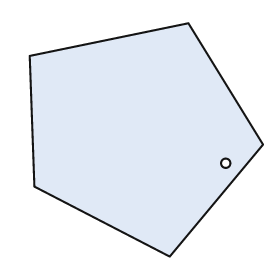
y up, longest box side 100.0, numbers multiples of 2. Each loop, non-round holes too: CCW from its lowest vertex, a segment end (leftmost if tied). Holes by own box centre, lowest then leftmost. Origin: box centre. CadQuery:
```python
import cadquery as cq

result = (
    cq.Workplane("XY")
    .moveTo(10.0, -50.0)
    .lineTo(50.0, -2.0)
    .lineTo(18.0, 50.0)
    .lineTo(-50.0, 36.0)
    .lineTo(-48.0, -20.0)
    .close()
    .moveTo(34.0, -10.0)
    .circle(2.0)
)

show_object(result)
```